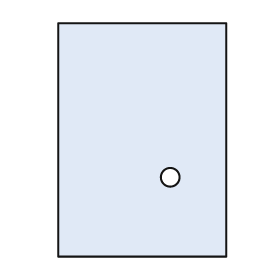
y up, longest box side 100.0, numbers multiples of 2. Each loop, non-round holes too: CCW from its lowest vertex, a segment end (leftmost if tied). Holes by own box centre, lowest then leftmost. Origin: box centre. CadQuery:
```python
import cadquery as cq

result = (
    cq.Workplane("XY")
    .moveTo(-36.0, -50.0)
    .lineTo(36.0, -50.0)
    .lineTo(36.0, 50.0)
    .lineTo(-36.0, 50.0)
    .close()
    .moveTo(12.0, -16.0)
    .circle(4.0)
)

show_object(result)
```